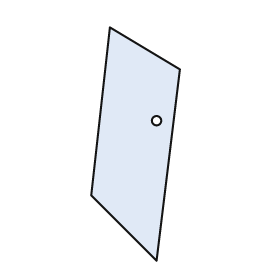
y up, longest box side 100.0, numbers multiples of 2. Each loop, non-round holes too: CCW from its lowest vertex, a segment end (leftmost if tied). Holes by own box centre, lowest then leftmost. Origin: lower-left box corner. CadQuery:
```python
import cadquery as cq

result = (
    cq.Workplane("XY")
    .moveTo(28.0, 0.0)
    .lineTo(38.0, 82.0)
    .lineTo(8.0, 100.0)
    .lineTo(0.0, 28.0)
    .close()
    .moveTo(28.0, 60.0)
    .circle(2.0)
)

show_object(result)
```